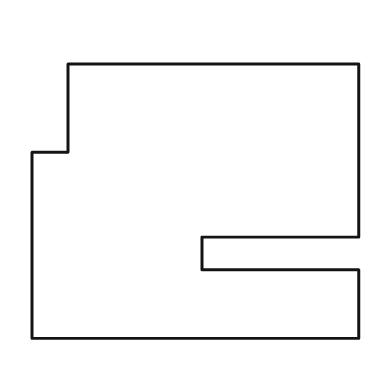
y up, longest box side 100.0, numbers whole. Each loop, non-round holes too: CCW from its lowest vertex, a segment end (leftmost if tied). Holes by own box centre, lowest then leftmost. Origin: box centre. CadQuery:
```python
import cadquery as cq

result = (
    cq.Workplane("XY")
    .moveTo(-50.0, -42.0)
    .lineTo(50.0, -42.0)
    .lineTo(50.0, -21.0)
    .lineTo(2.0, -21.0)
    .lineTo(2.0, -11.0)
    .lineTo(50.0, -11.0)
    .lineTo(50.0, 42.0)
    .lineTo(-39.0, 42.0)
    .lineTo(-39.0, 15.0)
    .lineTo(-50.0, 15.0)
    .close()
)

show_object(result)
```